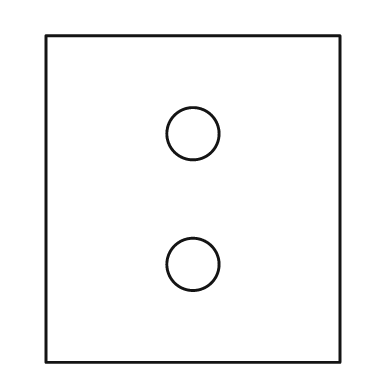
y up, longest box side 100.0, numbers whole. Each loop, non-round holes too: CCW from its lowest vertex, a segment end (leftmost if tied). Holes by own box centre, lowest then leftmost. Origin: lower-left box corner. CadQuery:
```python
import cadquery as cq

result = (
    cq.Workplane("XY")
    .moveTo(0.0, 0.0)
    .lineTo(90.0, 0.0)
    .lineTo(90.0, 100.0)
    .lineTo(0.0, 100.0)
    .close()
    .moveTo(45.0, 30.0)
    .circle(8.0)
    .moveTo(45.0, 70.0)
    .circle(8.0)
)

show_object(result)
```